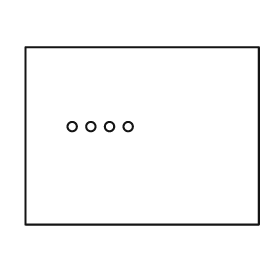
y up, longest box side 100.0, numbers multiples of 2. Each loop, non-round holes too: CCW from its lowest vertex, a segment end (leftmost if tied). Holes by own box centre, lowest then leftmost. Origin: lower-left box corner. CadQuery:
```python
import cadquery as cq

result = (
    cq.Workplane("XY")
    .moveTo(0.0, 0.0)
    .lineTo(100.0, 0.0)
    .lineTo(100.0, 76.0)
    .lineTo(0.0, 76.0)
    .close()
    .moveTo(20.0, 42.0)
    .circle(2.0)
    .moveTo(28.0, 42.0)
    .circle(2.0)
    .moveTo(36.0, 42.0)
    .circle(2.0)
    .moveTo(44.0, 42.0)
    .circle(2.0)
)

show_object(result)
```